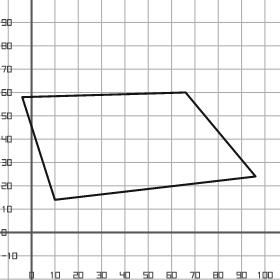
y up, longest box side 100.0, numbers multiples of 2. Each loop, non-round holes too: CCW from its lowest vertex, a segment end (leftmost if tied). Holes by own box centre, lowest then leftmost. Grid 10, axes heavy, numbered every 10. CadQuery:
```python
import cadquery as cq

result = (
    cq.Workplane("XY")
    .moveTo(10.0, 14.0)
    .lineTo(96.0, 24.0)
    .lineTo(66.0, 60.0)
    .lineTo(-4.0, 58.0)
    .close()
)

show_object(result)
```